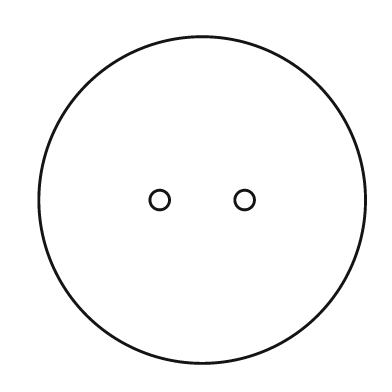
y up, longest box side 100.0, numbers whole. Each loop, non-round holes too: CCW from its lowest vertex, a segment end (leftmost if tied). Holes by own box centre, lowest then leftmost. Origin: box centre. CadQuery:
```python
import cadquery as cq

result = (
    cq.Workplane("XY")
    .moveTo(0.0, 0.0)
    .circle(50.0)
    .moveTo(-13.0, 0.0)
    .circle(3.0)
    .moveTo(13.0, 0.0)
    .circle(3.0)
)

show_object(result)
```